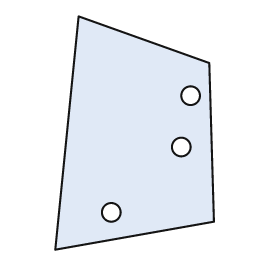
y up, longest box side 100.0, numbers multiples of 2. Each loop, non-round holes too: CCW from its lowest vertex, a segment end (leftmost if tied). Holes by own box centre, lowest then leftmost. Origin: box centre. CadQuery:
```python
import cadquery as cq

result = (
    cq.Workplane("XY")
    .moveTo(-34.0, -50.0)
    .lineTo(34.0, -38.0)
    .lineTo(32.0, 30.0)
    .lineTo(-24.0, 50.0)
    .close()
    .moveTo(-10.0, -34.0)
    .circle(4.0)
    .moveTo(20.0, -6.0)
    .circle(4.0)
    .moveTo(24.0, 16.0)
    .circle(4.0)
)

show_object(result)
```